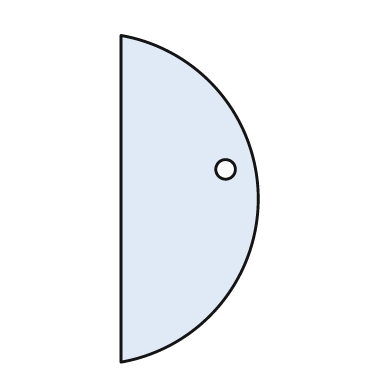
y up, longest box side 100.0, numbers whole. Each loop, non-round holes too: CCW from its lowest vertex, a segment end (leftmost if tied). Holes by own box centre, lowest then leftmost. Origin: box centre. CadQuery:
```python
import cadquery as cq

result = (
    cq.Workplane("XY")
    .moveTo(-21.0, -50.0)
    .threePointArc((21.0, 0.0), (-21.0, 50.0))
    .close()
    .moveTo(11.0, 9.0)
    .circle(3.0)
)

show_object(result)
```